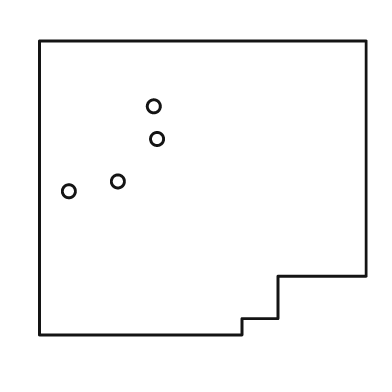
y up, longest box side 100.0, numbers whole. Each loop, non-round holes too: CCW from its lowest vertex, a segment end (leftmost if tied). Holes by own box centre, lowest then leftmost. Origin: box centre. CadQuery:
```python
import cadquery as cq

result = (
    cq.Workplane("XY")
    .moveTo(-50.0, -45.0)
    .lineTo(12.0, -45.0)
    .lineTo(12.0, -40.0)
    .lineTo(23.0, -40.0)
    .lineTo(23.0, -27.0)
    .lineTo(50.0, -27.0)
    .lineTo(50.0, 45.0)
    .lineTo(-50.0, 45.0)
    .close()
    .moveTo(-41.0, -1.0)
    .circle(2.0)
    .moveTo(-26.0, 2.0)
    .circle(2.0)
    .moveTo(-14.0, 15.0)
    .circle(2.0)
    .moveTo(-15.0, 25.0)
    .circle(2.0)
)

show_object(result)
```